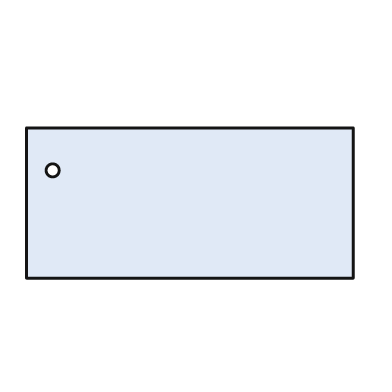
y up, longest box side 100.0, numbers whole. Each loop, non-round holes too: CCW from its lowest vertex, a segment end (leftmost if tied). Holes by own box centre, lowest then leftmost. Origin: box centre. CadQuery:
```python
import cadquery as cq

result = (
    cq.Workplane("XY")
    .moveTo(-50.0, -23.0)
    .lineTo(50.0, -23.0)
    .lineTo(50.0, 23.0)
    .lineTo(-50.0, 23.0)
    .close()
    .moveTo(-42.0, 10.0)
    .circle(2.0)
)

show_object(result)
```